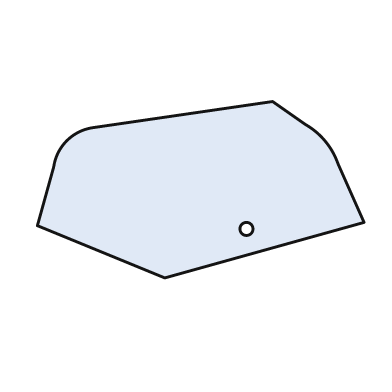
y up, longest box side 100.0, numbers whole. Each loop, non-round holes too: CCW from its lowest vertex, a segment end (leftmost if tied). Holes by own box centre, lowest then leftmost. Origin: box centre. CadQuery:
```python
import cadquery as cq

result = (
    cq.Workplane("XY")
    .moveTo(-11.0, -27.0)
    .lineTo(50.0, -10.0)
    .lineTo(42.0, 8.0)
    .threePointArc((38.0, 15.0), (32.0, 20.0))
    .lineTo(22.0, 27.0)
    .lineTo(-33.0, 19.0)
    .threePointArc((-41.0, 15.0), (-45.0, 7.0))
    .lineTo(-50.0, -11.0)
    .close()
    .moveTo(14.0, -12.0)
    .circle(2.0)
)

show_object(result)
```